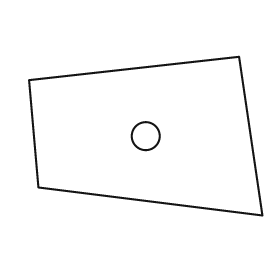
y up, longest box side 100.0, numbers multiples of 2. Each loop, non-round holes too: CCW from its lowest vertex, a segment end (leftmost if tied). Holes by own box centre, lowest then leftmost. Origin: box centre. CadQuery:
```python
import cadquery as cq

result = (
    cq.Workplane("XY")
    .moveTo(50.0, -34.0)
    .lineTo(40.0, 34.0)
    .lineTo(-50.0, 24.0)
    .lineTo(-46.0, -22.0)
    .close()
    .moveTo(0.0, 0.0)
    .circle(6.0)
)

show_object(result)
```